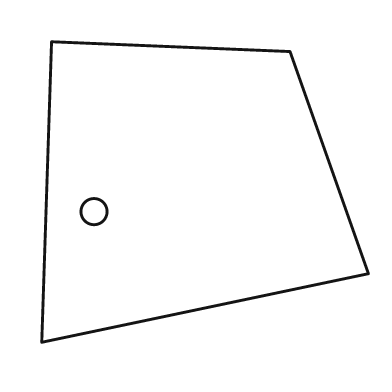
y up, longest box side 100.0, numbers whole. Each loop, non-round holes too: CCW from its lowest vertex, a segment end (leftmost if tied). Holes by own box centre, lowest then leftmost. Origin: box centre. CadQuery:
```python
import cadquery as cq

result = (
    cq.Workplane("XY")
    .moveTo(-50.0, -46.0)
    .lineTo(50.0, -25.0)
    .lineTo(26.0, 43.0)
    .lineTo(-47.0, 46.0)
    .close()
    .moveTo(-34.0, -6.0)
    .circle(4.0)
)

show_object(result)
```